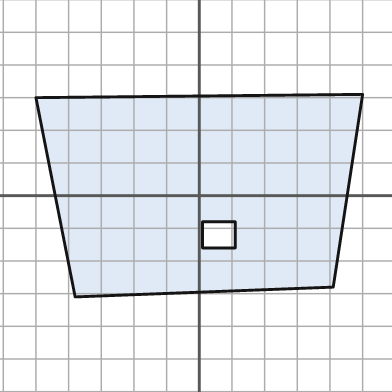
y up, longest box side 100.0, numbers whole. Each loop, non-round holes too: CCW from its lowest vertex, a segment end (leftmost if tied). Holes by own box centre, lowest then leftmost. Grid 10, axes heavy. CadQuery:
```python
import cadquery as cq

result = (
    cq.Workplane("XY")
    .moveTo(-38.0, -31.0)
    .lineTo(41.0, -28.0)
    .lineTo(50.0, 31.0)
    .lineTo(-50.0, 30.0)
    .close()
    .moveTo(1.0, -16.0)
    .lineTo(11.0, -16.0)
    .lineTo(11.0, -8.0)
    .lineTo(1.0, -8.0)
    .close()
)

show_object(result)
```